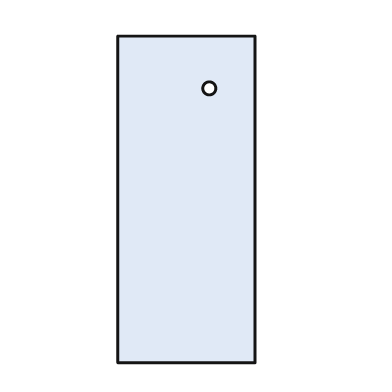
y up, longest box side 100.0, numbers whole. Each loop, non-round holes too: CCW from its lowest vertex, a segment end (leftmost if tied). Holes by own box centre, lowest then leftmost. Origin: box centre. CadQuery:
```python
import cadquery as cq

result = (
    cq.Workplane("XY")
    .moveTo(-21.0, -50.0)
    .lineTo(21.0, -50.0)
    .lineTo(21.0, 50.0)
    .lineTo(-21.0, 50.0)
    .close()
    .moveTo(7.0, 34.0)
    .circle(2.0)
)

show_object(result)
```